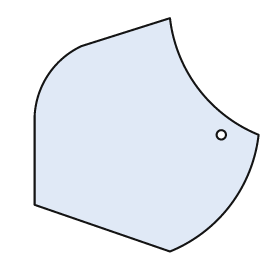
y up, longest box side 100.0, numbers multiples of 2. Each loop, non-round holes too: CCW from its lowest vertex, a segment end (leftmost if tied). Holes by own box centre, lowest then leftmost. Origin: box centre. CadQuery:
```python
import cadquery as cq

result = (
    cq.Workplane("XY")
    .moveTo(10.0, -50.0)
    .threePointArc((36.0, -30.0), (48.0, 0.0))
    .threePointArc((22.0, 20.0), (10.0, 50.0))
    .lineTo(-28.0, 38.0)
    .threePointArc((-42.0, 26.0), (-48.0, 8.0))
    .lineTo(-48.0, -30.0)
    .close()
    .moveTo(32.0, 0.0)
    .circle(2.0)
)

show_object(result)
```